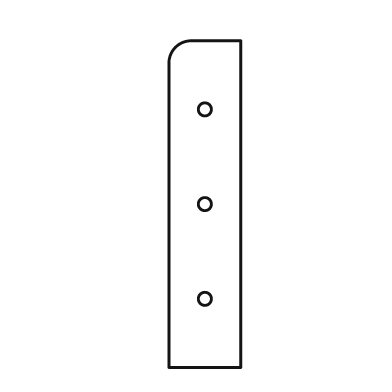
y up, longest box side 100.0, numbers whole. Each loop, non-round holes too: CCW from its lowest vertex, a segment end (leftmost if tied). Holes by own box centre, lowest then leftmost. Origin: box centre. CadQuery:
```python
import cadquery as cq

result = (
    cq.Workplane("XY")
    .moveTo(-11.0, -50.0)
    .lineTo(11.0, -50.0)
    .lineTo(11.0, 50.0)
    .lineTo(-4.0, 50.0)
    .threePointArc((-9.0, 48.0), (-11.0, 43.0))
    .close()
    .moveTo(0.0, -29.0)
    .circle(2.0)
    .moveTo(0.0, 0.0)
    .circle(2.0)
    .moveTo(0.0, 29.0)
    .circle(2.0)
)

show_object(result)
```